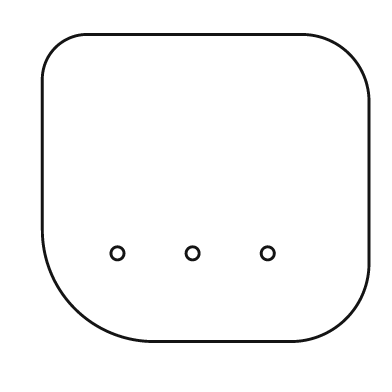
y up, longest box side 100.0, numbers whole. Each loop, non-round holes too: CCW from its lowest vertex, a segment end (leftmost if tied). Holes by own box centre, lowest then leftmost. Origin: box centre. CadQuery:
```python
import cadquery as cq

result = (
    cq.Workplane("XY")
    .moveTo(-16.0, -47.0)
    .lineTo(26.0, -47.0)
    .threePointArc((43.0, -40.0), (50.0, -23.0))
    .lineTo(50.0, 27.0)
    .threePointArc((44.0, 41.0), (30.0, 47.0))
    .lineTo(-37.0, 47.0)
    .threePointArc((-46.0, 43.0), (-50.0, 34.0))
    .lineTo(-50.0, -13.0)
    .threePointArc((-40.0, -37.0), (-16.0, -47.0))
    .close()
    .moveTo(-27.0, -20.0)
    .circle(2.0)
    .moveTo(-4.0, -20.0)
    .circle(2.0)
    .moveTo(19.0, -20.0)
    .circle(2.0)
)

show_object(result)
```